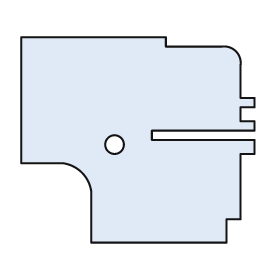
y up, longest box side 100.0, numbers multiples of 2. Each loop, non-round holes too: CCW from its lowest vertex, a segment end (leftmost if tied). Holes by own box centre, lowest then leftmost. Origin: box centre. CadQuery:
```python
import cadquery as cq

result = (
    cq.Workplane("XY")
    .moveTo(-20.0, -44.0)
    .lineTo(38.0, -44.0)
    .lineTo(38.0, -34.0)
    .lineTo(44.0, -34.0)
    .lineTo(44.0, -6.0)
    .lineTo(50.0, -6.0)
    .lineTo(50.0, 0.0)
    .lineTo(6.0, 0.0)
    .lineTo(6.0, 4.0)
    .lineTo(50.0, 4.0)
    .lineTo(50.0, 8.0)
    .lineTo(44.0, 8.0)
    .lineTo(44.0, 14.0)
    .lineTo(50.0, 14.0)
    .lineTo(50.0, 18.0)
    .lineTo(44.0, 18.0)
    .lineTo(44.0, 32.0)
    .threePointArc((42.0, 38.0), (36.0, 40.0))
    .lineTo(12.0, 40.0)
    .lineTo(12.0, 44.0)
    .lineTo(-50.0, 44.0)
    .lineTo(-50.0, -10.0)
    .lineTo(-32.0, -10.0)
    .threePointArc((-24.0, -14.0), (-20.0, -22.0))
    .close()
    .moveTo(-10.0, -2.0)
    .circle(4.0)
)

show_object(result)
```